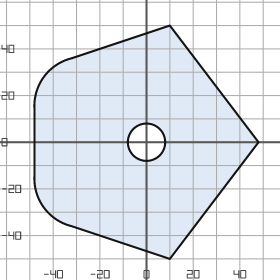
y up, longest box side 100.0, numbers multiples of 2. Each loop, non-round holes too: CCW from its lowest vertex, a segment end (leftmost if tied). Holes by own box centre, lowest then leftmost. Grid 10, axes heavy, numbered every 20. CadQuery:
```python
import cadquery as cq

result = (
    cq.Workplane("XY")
    .moveTo(10.0, -50.0)
    .lineTo(48.0, 0.0)
    .lineTo(10.0, 50.0)
    .lineTo(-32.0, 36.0)
    .threePointArc((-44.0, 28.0), (-48.0, 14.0))
    .lineTo(-48.0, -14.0)
    .threePointArc((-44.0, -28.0), (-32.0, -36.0))
    .close()
    .moveTo(0.0, 0.0)
    .circle(8.0)
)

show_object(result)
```